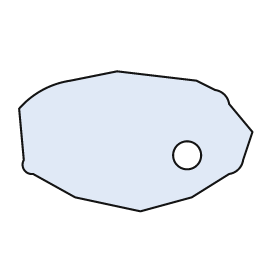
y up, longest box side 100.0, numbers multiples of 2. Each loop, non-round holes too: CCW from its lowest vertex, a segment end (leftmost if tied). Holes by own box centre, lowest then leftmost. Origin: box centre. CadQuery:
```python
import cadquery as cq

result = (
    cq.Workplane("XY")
    .moveTo(2.0, -30.0)
    .lineTo(24.0, -24.0)
    .lineTo(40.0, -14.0)
    .threePointArc((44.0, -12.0), (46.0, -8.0))
    .lineTo(50.0, 4.0)
    .lineTo(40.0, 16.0)
    .threePointArc((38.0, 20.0), (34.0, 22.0))
    .lineTo(26.0, 26.0)
    .lineTo(-8.0, 30.0)
    .lineTo(-28.0, 26.0)
    .threePointArc((-40.0, 22.0), (-50.0, 14.0))
    .lineTo(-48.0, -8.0)
    .threePointArc((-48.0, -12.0), (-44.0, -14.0))
    .lineTo(-26.0, -24.0)
    .close()
    .moveTo(22.0, -6.0)
    .circle(6.0)
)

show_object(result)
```